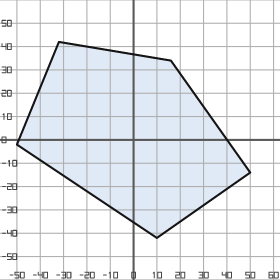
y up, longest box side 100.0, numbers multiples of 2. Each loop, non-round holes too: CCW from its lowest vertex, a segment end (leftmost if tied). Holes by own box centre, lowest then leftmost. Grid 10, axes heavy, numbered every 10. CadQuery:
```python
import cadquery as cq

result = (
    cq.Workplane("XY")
    .moveTo(10.0, -42.0)
    .lineTo(50.0, -14.0)
    .lineTo(16.0, 34.0)
    .lineTo(-32.0, 42.0)
    .lineTo(-50.0, -2.0)
    .close()
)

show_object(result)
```